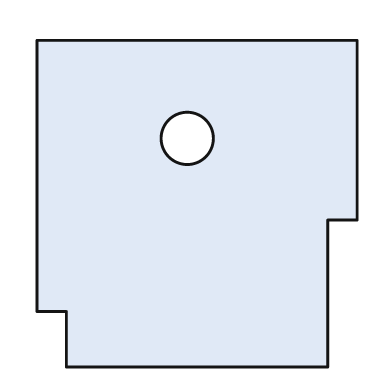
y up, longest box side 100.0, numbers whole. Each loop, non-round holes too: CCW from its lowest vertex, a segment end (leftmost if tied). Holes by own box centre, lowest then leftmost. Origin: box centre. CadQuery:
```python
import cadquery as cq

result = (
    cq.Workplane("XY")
    .moveTo(-40.0, -50.0)
    .lineTo(40.0, -50.0)
    .lineTo(40.0, -5.0)
    .lineTo(49.0, -5.0)
    .lineTo(49.0, 50.0)
    .lineTo(-49.0, 50.0)
    .lineTo(-49.0, -33.0)
    .lineTo(-40.0, -33.0)
    .close()
    .moveTo(-3.0, 20.0)
    .circle(8.0)
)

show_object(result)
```